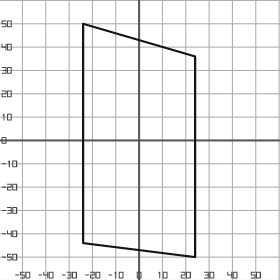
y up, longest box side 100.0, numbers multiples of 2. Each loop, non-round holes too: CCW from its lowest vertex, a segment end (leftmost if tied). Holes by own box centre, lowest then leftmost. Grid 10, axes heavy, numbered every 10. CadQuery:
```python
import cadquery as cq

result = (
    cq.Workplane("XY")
    .moveTo(24.0, -50.0)
    .lineTo(24.0, 36.0)
    .lineTo(-24.0, 50.0)
    .lineTo(-24.0, -44.0)
    .close()
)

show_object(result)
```